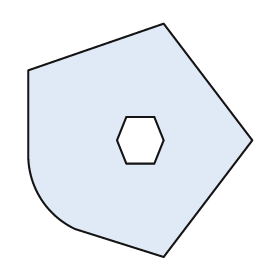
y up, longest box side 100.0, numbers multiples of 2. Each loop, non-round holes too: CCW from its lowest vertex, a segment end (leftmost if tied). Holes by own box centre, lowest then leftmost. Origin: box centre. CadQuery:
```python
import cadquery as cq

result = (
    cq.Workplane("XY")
    .moveTo(10.0, -50.0)
    .lineTo(48.0, 0.0)
    .lineTo(10.0, 50.0)
    .lineTo(-48.0, 30.0)
    .lineTo(-48.0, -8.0)
    .threePointArc((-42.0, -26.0), (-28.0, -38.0))
    .close()
    .moveTo(-6.0, -10.0)
    .lineTo(6.0, -10.0)
    .lineTo(10.0, 0.0)
    .lineTo(6.0, 10.0)
    .lineTo(-6.0, 10.0)
    .lineTo(-10.0, 0.0)
    .close()
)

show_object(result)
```